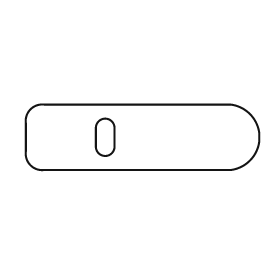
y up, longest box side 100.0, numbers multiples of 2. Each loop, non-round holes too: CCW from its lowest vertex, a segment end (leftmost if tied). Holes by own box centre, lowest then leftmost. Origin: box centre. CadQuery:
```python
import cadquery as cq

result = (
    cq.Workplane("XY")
    .moveTo(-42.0, -14.0)
    .lineTo(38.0, -14.0)
    .threePointArc((46.0, -10.0), (50.0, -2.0))
    .lineTo(50.0, 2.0)
    .threePointArc((46.0, 10.0), (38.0, 14.0))
    .lineTo(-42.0, 14.0)
    .threePointArc((-48.0, 12.0), (-50.0, 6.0))
    .lineTo(-50.0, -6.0)
    .threePointArc((-48.0, -12.0), (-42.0, -14.0))
    .close()
    .moveTo(-20.0, -4.0)
    .threePointArc((-16.0, -8.0), (-12.0, -4.0))
    .lineTo(-12.0, 4.0)
    .threePointArc((-16.0, 8.0), (-20.0, 4.0))
    .close()
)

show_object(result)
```